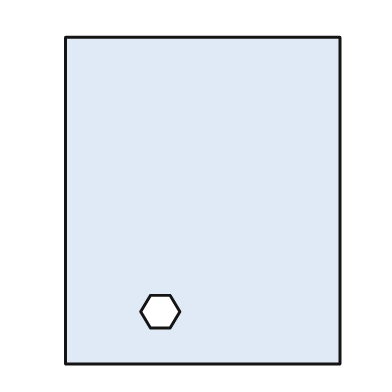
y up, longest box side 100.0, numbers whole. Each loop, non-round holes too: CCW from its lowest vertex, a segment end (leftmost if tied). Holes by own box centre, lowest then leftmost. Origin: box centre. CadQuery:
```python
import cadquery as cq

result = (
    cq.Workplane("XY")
    .moveTo(-42.0, -50.0)
    .lineTo(42.0, -50.0)
    .lineTo(42.0, 50.0)
    .lineTo(-42.0, 50.0)
    .close()
    .moveTo(-16.0, -39.0)
    .lineTo(-10.0, -39.0)
    .lineTo(-7.0, -34.0)
    .lineTo(-10.0, -29.0)
    .lineTo(-16.0, -29.0)
    .lineTo(-19.0, -34.0)
    .close()
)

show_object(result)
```